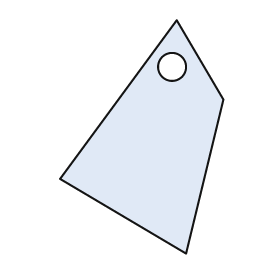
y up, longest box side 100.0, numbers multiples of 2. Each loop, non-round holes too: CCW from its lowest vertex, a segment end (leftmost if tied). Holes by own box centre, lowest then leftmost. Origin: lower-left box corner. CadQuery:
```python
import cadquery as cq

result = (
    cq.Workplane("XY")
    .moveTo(54.0, 0.0)
    .lineTo(70.0, 66.0)
    .lineTo(50.0, 100.0)
    .lineTo(0.0, 32.0)
    .close()
    .moveTo(48.0, 80.0)
    .circle(6.0)
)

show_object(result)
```